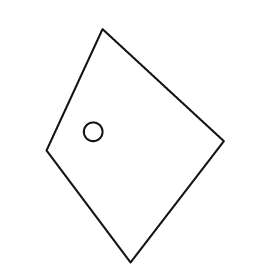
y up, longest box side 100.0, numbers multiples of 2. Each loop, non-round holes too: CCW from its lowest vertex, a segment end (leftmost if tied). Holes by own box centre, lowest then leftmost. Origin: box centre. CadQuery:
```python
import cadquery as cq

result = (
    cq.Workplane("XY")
    .moveTo(-2.0, -50.0)
    .lineTo(38.0, 2.0)
    .lineTo(-14.0, 50.0)
    .lineTo(-38.0, -2.0)
    .close()
    .moveTo(-18.0, 6.0)
    .circle(4.0)
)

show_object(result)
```